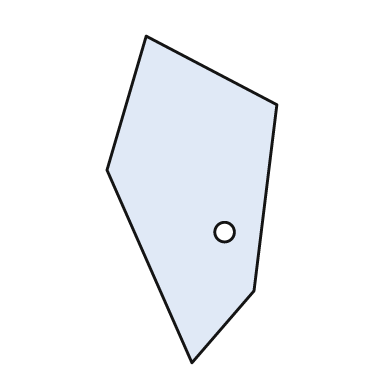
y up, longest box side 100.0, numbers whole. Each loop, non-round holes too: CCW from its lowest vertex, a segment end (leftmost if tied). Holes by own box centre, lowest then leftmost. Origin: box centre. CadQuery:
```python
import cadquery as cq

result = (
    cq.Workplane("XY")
    .moveTo(0.0, -50.0)
    .lineTo(19.0, -28.0)
    .lineTo(26.0, 29.0)
    .lineTo(-14.0, 50.0)
    .lineTo(-26.0, 9.0)
    .close()
    .moveTo(10.0, -10.0)
    .circle(3.0)
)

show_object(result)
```